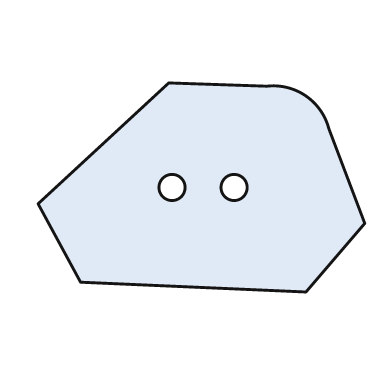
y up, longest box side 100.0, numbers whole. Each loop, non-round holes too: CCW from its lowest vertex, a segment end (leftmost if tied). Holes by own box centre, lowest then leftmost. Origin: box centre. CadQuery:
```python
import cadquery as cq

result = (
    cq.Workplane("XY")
    .moveTo(32.0, -32.0)
    .lineTo(50.0, -11.0)
    .lineTo(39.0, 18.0)
    .threePointArc((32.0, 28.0), (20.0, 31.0))
    .lineTo(-10.0, 32.0)
    .lineTo(-50.0, -5.0)
    .lineTo(-37.0, -29.0)
    .close()
    .moveTo(-9.0, 0.0)
    .circle(4.0)
    .moveTo(10.0, 0.0)
    .circle(4.0)
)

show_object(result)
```